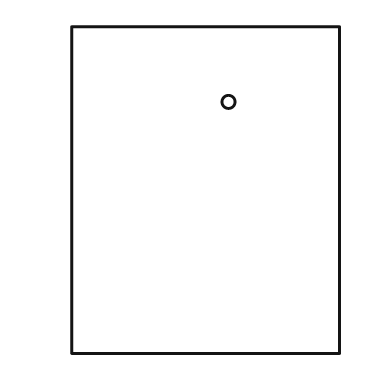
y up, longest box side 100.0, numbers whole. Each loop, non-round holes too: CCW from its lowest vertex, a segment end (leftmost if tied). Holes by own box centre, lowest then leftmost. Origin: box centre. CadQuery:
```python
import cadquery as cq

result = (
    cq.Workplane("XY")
    .moveTo(-41.0, -50.0)
    .lineTo(41.0, -50.0)
    .lineTo(41.0, 50.0)
    .lineTo(-41.0, 50.0)
    .close()
    .moveTo(7.0, 27.0)
    .circle(2.0)
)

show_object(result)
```